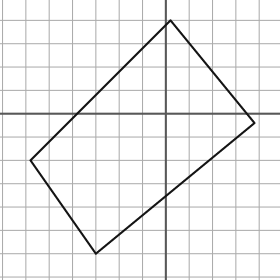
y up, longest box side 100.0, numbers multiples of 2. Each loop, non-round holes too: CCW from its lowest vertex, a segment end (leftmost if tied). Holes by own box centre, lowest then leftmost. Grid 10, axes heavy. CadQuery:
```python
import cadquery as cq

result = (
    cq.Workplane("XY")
    .moveTo(-30.0, -60.0)
    .lineTo(38.0, -4.0)
    .lineTo(2.0, 40.0)
    .lineTo(-58.0, -20.0)
    .close()
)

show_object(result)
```